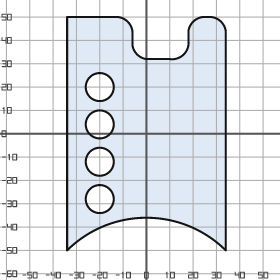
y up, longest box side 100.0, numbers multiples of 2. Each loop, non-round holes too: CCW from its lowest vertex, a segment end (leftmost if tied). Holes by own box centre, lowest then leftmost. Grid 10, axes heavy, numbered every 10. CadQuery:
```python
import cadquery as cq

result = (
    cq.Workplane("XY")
    .moveTo(-34.0, -50.0)
    .threePointArc((0.0, -36.0), (34.0, -50.0))
    .lineTo(34.0, 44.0)
    .threePointArc((32.0, 48.0), (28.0, 50.0))
    .lineTo(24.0, 50.0)
    .threePointArc((20.0, 48.0), (18.0, 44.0))
    .lineTo(18.0, 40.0)
    .threePointArc((16.0, 34.0), (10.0, 32.0))
    .lineTo(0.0, 32.0)
    .threePointArc((-4.0, 34.0), (-6.0, 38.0))
    .lineTo(-6.0, 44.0)
    .threePointArc((-8.0, 48.0), (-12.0, 50.0))
    .lineTo(-34.0, 50.0)
    .close()
    .moveTo(-20.0, -28.0)
    .circle(6.0)
    .moveTo(-20.0, -12.0)
    .circle(6.0)
    .moveTo(-20.0, 4.0)
    .circle(6.0)
    .moveTo(-20.0, 20.0)
    .circle(6.0)
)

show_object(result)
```